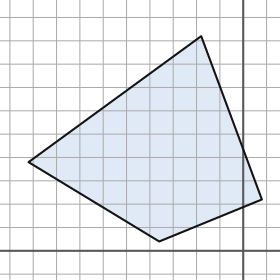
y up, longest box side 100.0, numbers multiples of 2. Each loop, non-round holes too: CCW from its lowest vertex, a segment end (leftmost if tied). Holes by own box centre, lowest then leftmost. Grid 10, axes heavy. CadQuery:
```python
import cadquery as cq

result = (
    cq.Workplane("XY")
    .moveTo(-36.0, 4.0)
    .lineTo(8.0, 22.0)
    .lineTo(-18.0, 92.0)
    .lineTo(-92.0, 38.0)
    .close()
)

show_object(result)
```